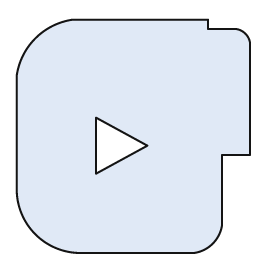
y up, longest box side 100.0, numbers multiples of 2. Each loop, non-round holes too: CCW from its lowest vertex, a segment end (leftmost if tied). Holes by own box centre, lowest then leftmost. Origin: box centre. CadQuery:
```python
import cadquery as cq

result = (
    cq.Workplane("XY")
    .moveTo(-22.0, -50.0)
    .lineTo(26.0, -50.0)
    .threePointArc((34.0, -46.0), (38.0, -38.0))
    .lineTo(38.0, -8.0)
    .lineTo(50.0, -8.0)
    .lineTo(50.0, 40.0)
    .threePointArc((48.0, 44.0), (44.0, 46.0))
    .lineTo(32.0, 46.0)
    .lineTo(32.0, 50.0)
    .lineTo(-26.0, 50.0)
    .threePointArc((-42.0, 42.0), (-50.0, 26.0))
    .lineTo(-50.0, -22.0)
    .threePointArc((-42.0, -42.0), (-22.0, -50.0))
    .close()
    .moveTo(-16.0, -16.0)
    .lineTo(6.0, -4.0)
    .lineTo(-16.0, 8.0)
    .close()
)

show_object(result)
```